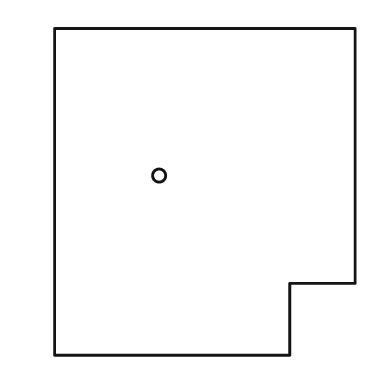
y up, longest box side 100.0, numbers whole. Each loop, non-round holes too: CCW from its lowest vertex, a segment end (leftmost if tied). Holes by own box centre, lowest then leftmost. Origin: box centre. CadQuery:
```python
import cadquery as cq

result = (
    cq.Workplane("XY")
    .moveTo(-46.0, -50.0)
    .lineTo(26.0, -50.0)
    .lineTo(26.0, -28.0)
    .lineTo(46.0, -28.0)
    .lineTo(46.0, 50.0)
    .lineTo(-46.0, 50.0)
    .close()
    .moveTo(-14.0, 5.0)
    .circle(2.0)
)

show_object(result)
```